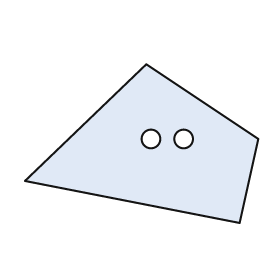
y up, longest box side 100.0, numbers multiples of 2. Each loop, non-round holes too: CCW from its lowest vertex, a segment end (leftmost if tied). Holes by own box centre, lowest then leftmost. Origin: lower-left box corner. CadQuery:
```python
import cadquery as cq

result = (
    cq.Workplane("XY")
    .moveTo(92.0, 0.0)
    .lineTo(100.0, 36.0)
    .lineTo(52.0, 68.0)
    .lineTo(0.0, 18.0)
    .close()
    .moveTo(54.0, 36.0)
    .circle(4.0)
    .moveTo(68.0, 36.0)
    .circle(4.0)
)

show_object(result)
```